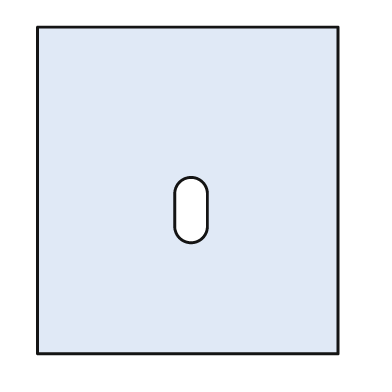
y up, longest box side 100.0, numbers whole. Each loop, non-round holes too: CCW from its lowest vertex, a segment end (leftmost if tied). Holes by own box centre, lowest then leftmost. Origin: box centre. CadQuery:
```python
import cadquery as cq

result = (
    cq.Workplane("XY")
    .moveTo(-46.0, -50.0)
    .lineTo(46.0, -50.0)
    .lineTo(46.0, 50.0)
    .lineTo(-46.0, 50.0)
    .close()
    .moveTo(-4.0, -11.0)
    .threePointArc((1.0, -16.0), (6.0, -11.0))
    .lineTo(6.0, -1.0)
    .threePointArc((1.0, 4.0), (-4.0, -1.0))
    .close()
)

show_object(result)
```